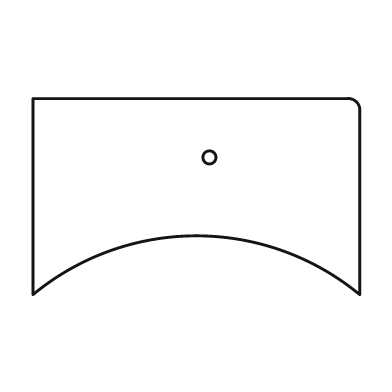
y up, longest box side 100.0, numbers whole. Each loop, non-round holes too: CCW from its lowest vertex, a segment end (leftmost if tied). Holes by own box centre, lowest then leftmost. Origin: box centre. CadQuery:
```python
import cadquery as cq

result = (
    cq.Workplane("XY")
    .moveTo(-50.0, -30.0)
    .threePointArc((0.0, -12.0), (50.0, -30.0))
    .lineTo(50.0, 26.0)
    .threePointArc((49.0, 29.0), (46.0, 30.0))
    .lineTo(-50.0, 30.0)
    .close()
    .moveTo(4.0, 12.0)
    .circle(2.0)
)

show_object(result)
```